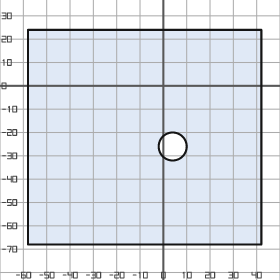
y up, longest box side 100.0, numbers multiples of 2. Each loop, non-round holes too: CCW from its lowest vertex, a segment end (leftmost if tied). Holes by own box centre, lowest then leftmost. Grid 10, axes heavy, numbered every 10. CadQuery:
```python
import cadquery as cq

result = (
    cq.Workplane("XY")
    .moveTo(-58.0, -68.0)
    .lineTo(42.0, -68.0)
    .lineTo(42.0, 24.0)
    .lineTo(-58.0, 24.0)
    .close()
    .moveTo(4.0, -26.0)
    .circle(6.0)
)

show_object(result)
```